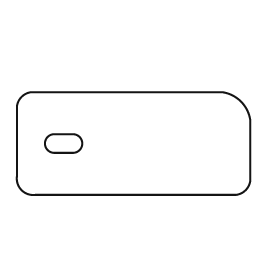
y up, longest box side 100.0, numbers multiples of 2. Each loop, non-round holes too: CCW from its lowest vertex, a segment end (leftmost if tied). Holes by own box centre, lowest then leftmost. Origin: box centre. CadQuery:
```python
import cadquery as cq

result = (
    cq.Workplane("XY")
    .moveTo(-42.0, -22.0)
    .lineTo(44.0, -22.0)
    .threePointArc((48.0, -20.0), (50.0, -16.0))
    .lineTo(50.0, 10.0)
    .threePointArc((46.0, 18.0), (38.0, 22.0))
    .lineTo(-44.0, 22.0)
    .threePointArc((-48.0, 20.0), (-50.0, 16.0))
    .lineTo(-50.0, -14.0)
    .threePointArc((-48.0, -20.0), (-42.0, -22.0))
    .close()
    .moveTo(-34.0, -4.0)
    .lineTo(-26.0, -4.0)
    .threePointArc((-22.0, 0.0), (-26.0, 4.0))
    .lineTo(-34.0, 4.0)
    .threePointArc((-38.0, 0.0), (-34.0, -4.0))
    .close()
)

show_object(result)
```